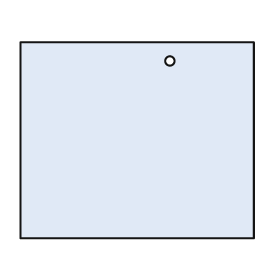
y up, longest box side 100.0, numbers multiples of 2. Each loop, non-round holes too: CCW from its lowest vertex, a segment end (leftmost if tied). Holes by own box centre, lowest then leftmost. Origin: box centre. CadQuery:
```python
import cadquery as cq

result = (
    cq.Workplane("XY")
    .moveTo(-50.0, -42.0)
    .lineTo(50.0, -42.0)
    .lineTo(50.0, 42.0)
    .lineTo(-50.0, 42.0)
    .close()
    .moveTo(14.0, 34.0)
    .circle(2.0)
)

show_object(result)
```